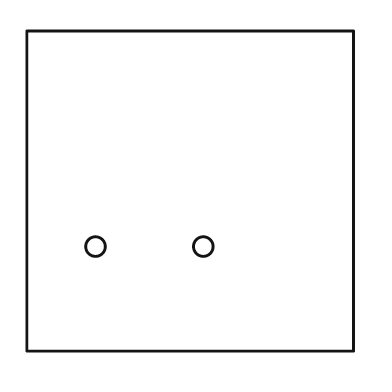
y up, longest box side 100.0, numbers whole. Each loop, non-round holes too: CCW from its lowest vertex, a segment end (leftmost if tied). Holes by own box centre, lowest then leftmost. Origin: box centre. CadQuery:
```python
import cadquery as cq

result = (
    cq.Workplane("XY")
    .moveTo(-50.0, -49.0)
    .lineTo(50.0, -49.0)
    .lineTo(50.0, 49.0)
    .lineTo(-50.0, 49.0)
    .close()
    .moveTo(-29.0, -17.0)
    .circle(3.0)
    .moveTo(4.0, -17.0)
    .circle(3.0)
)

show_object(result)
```